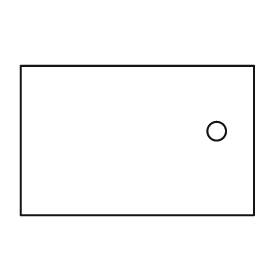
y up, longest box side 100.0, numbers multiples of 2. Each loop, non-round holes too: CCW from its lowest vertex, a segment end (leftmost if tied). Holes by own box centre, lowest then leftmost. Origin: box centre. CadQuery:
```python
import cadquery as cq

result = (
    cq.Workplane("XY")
    .moveTo(-50.0, -32.0)
    .lineTo(50.0, -32.0)
    .lineTo(50.0, 32.0)
    .lineTo(-50.0, 32.0)
    .close()
    .moveTo(34.0, 4.0)
    .circle(4.0)
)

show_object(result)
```